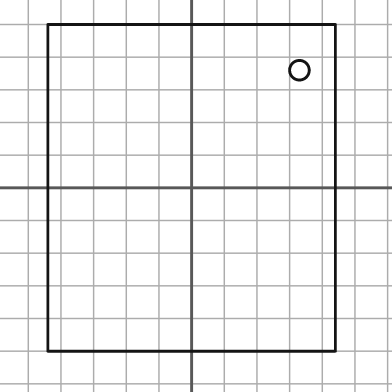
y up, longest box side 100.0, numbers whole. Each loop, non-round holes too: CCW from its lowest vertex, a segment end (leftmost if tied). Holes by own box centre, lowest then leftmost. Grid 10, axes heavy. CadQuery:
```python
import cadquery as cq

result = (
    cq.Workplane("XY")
    .moveTo(-44.0, -50.0)
    .lineTo(44.0, -50.0)
    .lineTo(44.0, 50.0)
    .lineTo(-44.0, 50.0)
    .close()
    .moveTo(33.0, 36.0)
    .circle(3.0)
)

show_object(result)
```